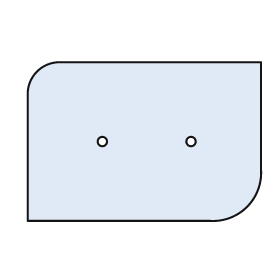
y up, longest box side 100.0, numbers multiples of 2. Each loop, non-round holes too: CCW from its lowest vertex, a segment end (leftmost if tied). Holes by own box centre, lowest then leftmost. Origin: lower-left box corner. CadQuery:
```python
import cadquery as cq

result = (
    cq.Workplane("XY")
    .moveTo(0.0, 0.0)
    .lineTo(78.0, 0.0)
    .threePointArc((94.0, 6.0), (100.0, 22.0))
    .lineTo(100.0, 68.0)
    .lineTo(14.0, 68.0)
    .threePointArc((4.0, 64.0), (0.0, 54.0))
    .close()
    .moveTo(32.0, 34.0)
    .circle(2.0)
    .moveTo(70.0, 34.0)
    .circle(2.0)
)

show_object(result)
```